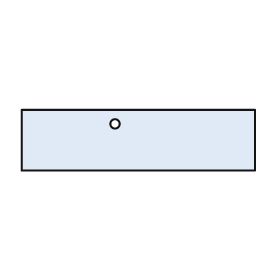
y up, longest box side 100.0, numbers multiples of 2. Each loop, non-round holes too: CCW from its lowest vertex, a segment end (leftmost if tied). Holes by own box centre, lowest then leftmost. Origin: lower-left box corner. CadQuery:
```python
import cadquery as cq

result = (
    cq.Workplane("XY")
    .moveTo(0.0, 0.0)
    .lineTo(100.0, 0.0)
    .lineTo(100.0, 26.0)
    .lineTo(0.0, 26.0)
    .close()
    .moveTo(40.0, 20.0)
    .circle(2.0)
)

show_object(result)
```